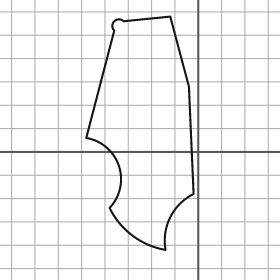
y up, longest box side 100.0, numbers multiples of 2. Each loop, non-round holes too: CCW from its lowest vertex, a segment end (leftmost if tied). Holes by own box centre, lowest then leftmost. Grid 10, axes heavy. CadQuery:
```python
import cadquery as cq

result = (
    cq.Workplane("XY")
    .moveTo(-14.0, -42.0)
    .threePointArc((-12.0, -28.0), (-2.0, -18.0))
    .lineTo(-4.0, 28.0)
    .lineTo(-12.0, 58.0)
    .lineTo(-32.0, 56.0)
    .threePointArc((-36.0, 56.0), (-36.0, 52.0))
    .lineTo(-48.0, 6.0)
    .threePointArc((-34.0, -6.0), (-38.0, -24.0))
    .threePointArc((-28.0, -36.0), (-14.0, -42.0))
    .close()
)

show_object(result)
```